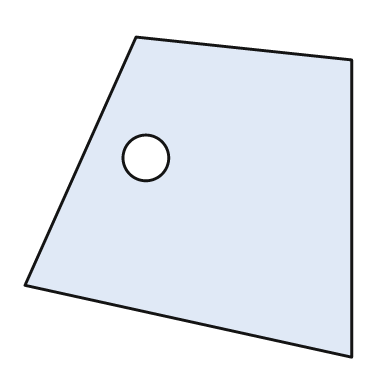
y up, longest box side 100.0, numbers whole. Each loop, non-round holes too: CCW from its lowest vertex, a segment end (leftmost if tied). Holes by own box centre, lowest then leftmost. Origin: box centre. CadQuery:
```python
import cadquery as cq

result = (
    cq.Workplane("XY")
    .moveTo(50.0, -49.0)
    .lineTo(50.0, 42.0)
    .lineTo(-16.0, 49.0)
    .lineTo(-50.0, -27.0)
    .close()
    .moveTo(-13.0, 12.0)
    .circle(7.0)
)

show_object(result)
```